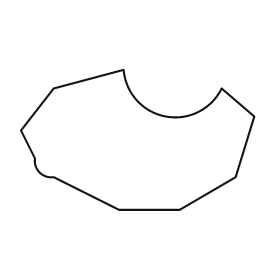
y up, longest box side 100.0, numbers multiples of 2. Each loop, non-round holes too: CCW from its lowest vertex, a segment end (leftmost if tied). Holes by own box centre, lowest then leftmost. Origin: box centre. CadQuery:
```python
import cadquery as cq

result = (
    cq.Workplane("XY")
    .moveTo(-8.0, -30.0)
    .lineTo(18.0, -30.0)
    .lineTo(42.0, -16.0)
    .lineTo(50.0, 10.0)
    .lineTo(36.0, 22.0)
    .threePointArc((12.0, 10.0), (-6.0, 30.0))
    .lineTo(-36.0, 22.0)
    .lineTo(-50.0, 4.0)
    .lineTo(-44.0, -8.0)
    .threePointArc((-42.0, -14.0), (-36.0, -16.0))
    .close()
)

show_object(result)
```